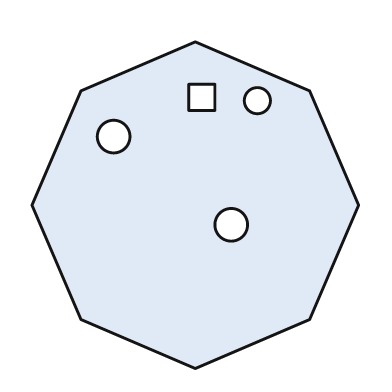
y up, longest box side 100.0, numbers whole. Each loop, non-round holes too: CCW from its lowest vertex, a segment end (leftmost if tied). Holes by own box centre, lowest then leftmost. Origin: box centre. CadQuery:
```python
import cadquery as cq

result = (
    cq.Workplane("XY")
    .moveTo(0.0, -50.0)
    .lineTo(35.0, -35.0)
    .lineTo(50.0, 0.0)
    .lineTo(35.0, 35.0)
    .lineTo(0.0, 50.0)
    .lineTo(-35.0, 35.0)
    .lineTo(-50.0, 0.0)
    .lineTo(-35.0, -35.0)
    .close()
    .moveTo(11.0, -6.0)
    .circle(5.0)
    .moveTo(-25.0, 21.0)
    .circle(5.0)
    .moveTo(19.0, 32.0)
    .circle(4.0)
    .moveTo(-2.0, 29.0)
    .lineTo(6.0, 29.0)
    .lineTo(6.0, 37.0)
    .lineTo(-2.0, 37.0)
    .close()
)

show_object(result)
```